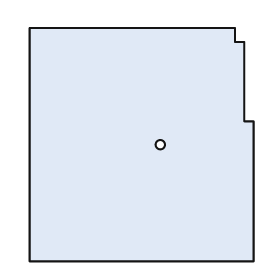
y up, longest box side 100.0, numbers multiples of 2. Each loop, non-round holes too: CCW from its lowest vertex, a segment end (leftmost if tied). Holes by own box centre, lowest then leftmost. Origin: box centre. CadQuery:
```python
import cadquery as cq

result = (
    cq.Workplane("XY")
    .moveTo(-48.0, -50.0)
    .lineTo(48.0, -50.0)
    .lineTo(48.0, 10.0)
    .lineTo(44.0, 10.0)
    .lineTo(44.0, 44.0)
    .lineTo(40.0, 44.0)
    .lineTo(40.0, 50.0)
    .lineTo(-48.0, 50.0)
    .close()
    .moveTo(8.0, 0.0)
    .circle(2.0)
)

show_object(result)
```